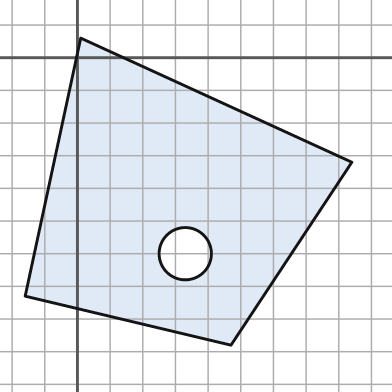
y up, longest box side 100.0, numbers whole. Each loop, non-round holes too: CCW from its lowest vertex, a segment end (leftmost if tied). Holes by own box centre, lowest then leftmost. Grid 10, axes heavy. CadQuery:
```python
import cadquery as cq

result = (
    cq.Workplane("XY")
    .moveTo(47.0, -88.0)
    .lineTo(84.0, -32.0)
    .lineTo(1.0, 6.0)
    .lineTo(-16.0, -73.0)
    .close()
    .moveTo(33.0, -60.0)
    .circle(8.0)
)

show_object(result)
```